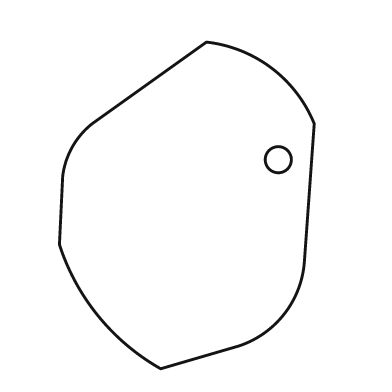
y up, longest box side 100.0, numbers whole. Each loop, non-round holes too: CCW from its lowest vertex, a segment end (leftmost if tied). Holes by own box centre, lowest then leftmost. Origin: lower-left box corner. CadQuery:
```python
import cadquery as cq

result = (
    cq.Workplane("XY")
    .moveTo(31.0, 0.0)
    .lineTo(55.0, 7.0)
    .threePointArc((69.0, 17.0), (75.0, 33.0))
    .lineTo(78.0, 75.0)
    .threePointArc((65.0, 92.0), (45.0, 100.0))
    .lineTo(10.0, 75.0)
    .threePointArc((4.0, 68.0), (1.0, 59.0))
    .lineTo(0.0, 38.0)
    .threePointArc((12.0, 16.0), (31.0, 0.0))
    .close()
    .moveTo(67.0, 64.0)
    .circle(4.0)
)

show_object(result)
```